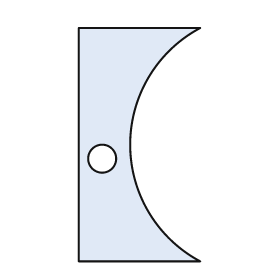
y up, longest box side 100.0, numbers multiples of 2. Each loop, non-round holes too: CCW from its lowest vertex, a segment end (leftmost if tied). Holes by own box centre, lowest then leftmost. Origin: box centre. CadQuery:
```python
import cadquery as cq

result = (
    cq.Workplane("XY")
    .moveTo(-26.0, -50.0)
    .lineTo(26.0, -50.0)
    .threePointArc((-4.0, 0.0), (26.0, 50.0))
    .lineTo(-26.0, 50.0)
    .close()
    .moveTo(-16.0, -6.0)
    .circle(6.0)
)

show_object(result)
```